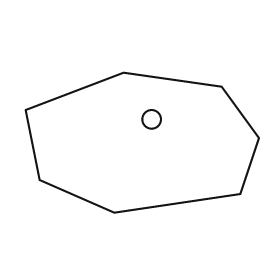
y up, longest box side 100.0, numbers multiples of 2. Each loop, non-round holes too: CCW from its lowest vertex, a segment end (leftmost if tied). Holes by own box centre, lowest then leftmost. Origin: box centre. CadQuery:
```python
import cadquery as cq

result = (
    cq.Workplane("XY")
    .moveTo(-12.0, -30.0)
    .lineTo(42.0, -22.0)
    .lineTo(50.0, 2.0)
    .lineTo(34.0, 24.0)
    .lineTo(-8.0, 30.0)
    .lineTo(-50.0, 14.0)
    .lineTo(-44.0, -16.0)
    .close()
    .moveTo(4.0, 10.0)
    .circle(4.0)
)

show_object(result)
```